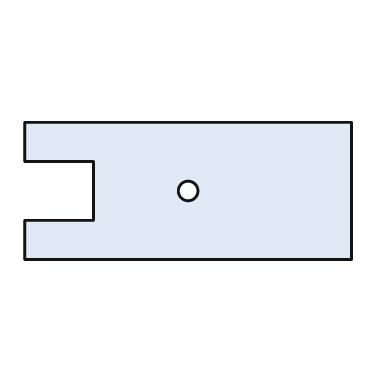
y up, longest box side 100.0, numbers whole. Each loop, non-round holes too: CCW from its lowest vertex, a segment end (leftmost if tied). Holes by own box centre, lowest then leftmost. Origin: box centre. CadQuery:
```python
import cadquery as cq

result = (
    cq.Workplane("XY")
    .moveTo(-50.0, -21.0)
    .lineTo(50.0, -21.0)
    .lineTo(50.0, 21.0)
    .lineTo(-50.0, 21.0)
    .lineTo(-50.0, 9.0)
    .lineTo(-29.0, 9.0)
    .lineTo(-29.0, -9.0)
    .lineTo(-50.0, -9.0)
    .close()
    .moveTo(0.0, 0.0)
    .circle(3.0)
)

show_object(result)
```